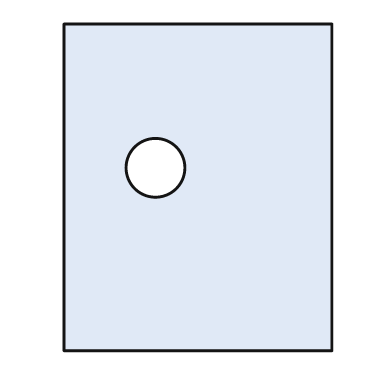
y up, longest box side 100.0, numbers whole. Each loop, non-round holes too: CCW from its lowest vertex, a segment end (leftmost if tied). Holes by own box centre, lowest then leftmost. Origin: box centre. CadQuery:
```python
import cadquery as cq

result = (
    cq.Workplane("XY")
    .moveTo(-41.0, -50.0)
    .lineTo(41.0, -50.0)
    .lineTo(41.0, 50.0)
    .lineTo(-41.0, 50.0)
    .close()
    .moveTo(-13.0, 6.0)
    .circle(9.0)
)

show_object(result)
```